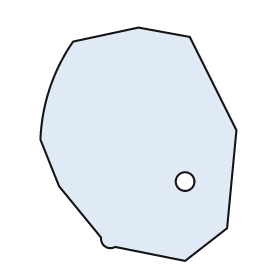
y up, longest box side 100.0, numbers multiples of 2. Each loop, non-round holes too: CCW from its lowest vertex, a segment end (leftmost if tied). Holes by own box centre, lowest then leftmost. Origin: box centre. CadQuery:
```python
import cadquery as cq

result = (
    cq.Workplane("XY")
    .moveTo(20.0, -50.0)
    .lineTo(38.0, -36.0)
    .lineTo(42.0, 6.0)
    .lineTo(22.0, 46.0)
    .lineTo(0.0, 50.0)
    .lineTo(-28.0, 44.0)
    .threePointArc((-38.0, 24.0), (-42.0, 2.0))
    .lineTo(-34.0, -18.0)
    .lineTo(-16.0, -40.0)
    .threePointArc((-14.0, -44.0), (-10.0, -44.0))
    .close()
    .moveTo(20.0, -16.0)
    .circle(4.0)
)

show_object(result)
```